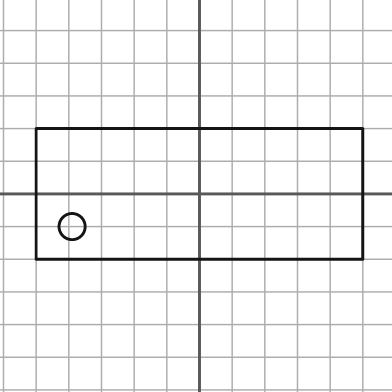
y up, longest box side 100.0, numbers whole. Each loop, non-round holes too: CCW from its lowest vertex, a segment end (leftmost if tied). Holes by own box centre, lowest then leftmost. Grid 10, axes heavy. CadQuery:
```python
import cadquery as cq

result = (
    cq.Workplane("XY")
    .moveTo(-50.0, -20.0)
    .lineTo(50.0, -20.0)
    .lineTo(50.0, 20.0)
    .lineTo(-50.0, 20.0)
    .close()
    .moveTo(-39.0, -10.0)
    .circle(4.0)
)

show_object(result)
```